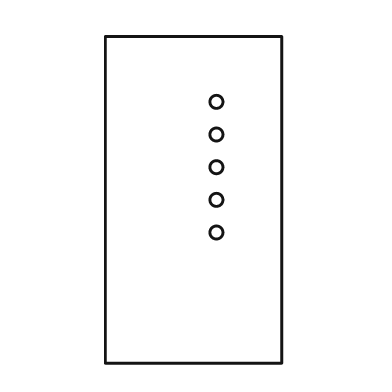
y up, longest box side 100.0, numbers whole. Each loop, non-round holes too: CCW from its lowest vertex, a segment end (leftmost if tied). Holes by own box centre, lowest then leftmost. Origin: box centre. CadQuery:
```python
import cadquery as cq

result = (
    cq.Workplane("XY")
    .moveTo(-27.0, -50.0)
    .lineTo(27.0, -50.0)
    .lineTo(27.0, 50.0)
    .lineTo(-27.0, 50.0)
    .close()
    .moveTo(7.0, -10.0)
    .circle(2.0)
    .moveTo(7.0, 0.0)
    .circle(2.0)
    .moveTo(7.0, 10.0)
    .circle(2.0)
    .moveTo(7.0, 20.0)
    .circle(2.0)
    .moveTo(7.0, 30.0)
    .circle(2.0)
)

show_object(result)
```